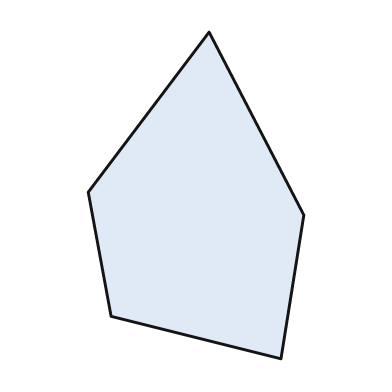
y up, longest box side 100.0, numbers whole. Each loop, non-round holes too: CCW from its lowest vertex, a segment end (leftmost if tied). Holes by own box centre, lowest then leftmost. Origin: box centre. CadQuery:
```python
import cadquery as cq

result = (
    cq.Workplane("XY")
    .moveTo(26.0, -50.0)
    .lineTo(33.0, -6.0)
    .lineTo(4.0, 50.0)
    .lineTo(-33.0, 1.0)
    .lineTo(-26.0, -37.0)
    .close()
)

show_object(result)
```